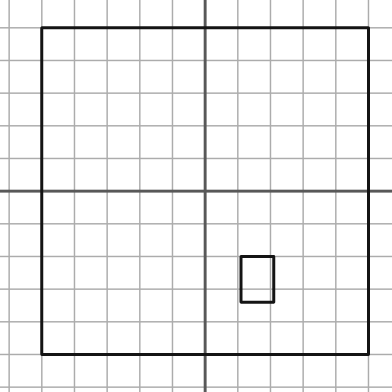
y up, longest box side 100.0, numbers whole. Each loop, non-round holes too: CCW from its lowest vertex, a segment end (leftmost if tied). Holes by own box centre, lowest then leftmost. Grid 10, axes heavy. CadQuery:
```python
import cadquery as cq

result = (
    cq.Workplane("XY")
    .moveTo(-50.0, -50.0)
    .lineTo(50.0, -50.0)
    .lineTo(50.0, 50.0)
    .lineTo(-50.0, 50.0)
    .close()
    .moveTo(11.0, -34.0)
    .lineTo(21.0, -34.0)
    .lineTo(21.0, -20.0)
    .lineTo(11.0, -20.0)
    .close()
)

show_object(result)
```